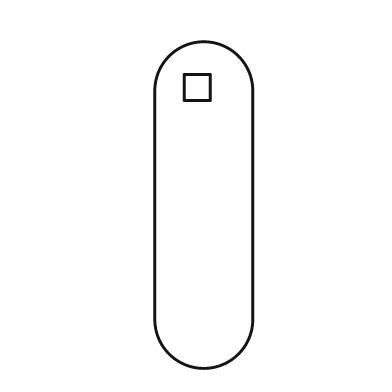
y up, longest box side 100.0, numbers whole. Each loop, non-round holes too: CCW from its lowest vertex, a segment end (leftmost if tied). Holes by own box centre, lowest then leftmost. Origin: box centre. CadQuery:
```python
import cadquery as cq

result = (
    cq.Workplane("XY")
    .moveTo(-15.0, -35.0)
    .threePointArc((0.0, -50.0), (15.0, -35.0))
    .lineTo(15.0, 35.0)
    .threePointArc((0.0, 50.0), (-15.0, 35.0))
    .close()
    .moveTo(-6.0, 32.0)
    .lineTo(2.0, 32.0)
    .lineTo(2.0, 40.0)
    .lineTo(-6.0, 40.0)
    .close()
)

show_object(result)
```